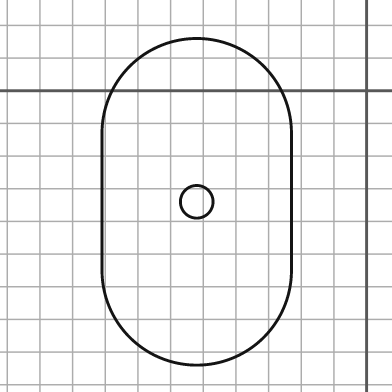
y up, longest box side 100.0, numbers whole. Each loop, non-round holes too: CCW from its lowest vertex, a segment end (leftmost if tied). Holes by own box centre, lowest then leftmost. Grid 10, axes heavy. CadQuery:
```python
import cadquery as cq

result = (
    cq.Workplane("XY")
    .moveTo(-81.0, -55.0)
    .threePointArc((-52.0, -84.0), (-23.0, -55.0))
    .lineTo(-23.0, -13.0)
    .threePointArc((-52.0, 16.0), (-81.0, -13.0))
    .close()
    .moveTo(-52.0, -34.0)
    .circle(5.0)
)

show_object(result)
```